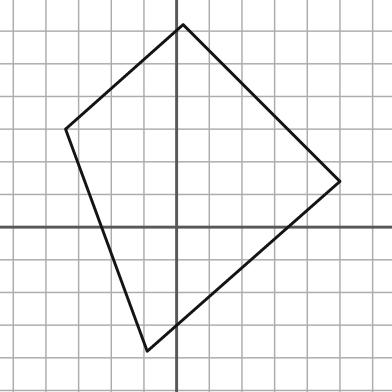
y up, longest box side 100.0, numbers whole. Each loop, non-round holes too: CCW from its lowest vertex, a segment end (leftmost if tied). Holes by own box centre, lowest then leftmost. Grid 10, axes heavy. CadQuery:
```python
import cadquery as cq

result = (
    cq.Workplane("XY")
    .moveTo(-9.0, -38.0)
    .lineTo(50.0, 14.0)
    .lineTo(2.0, 62.0)
    .lineTo(-34.0, 30.0)
    .close()
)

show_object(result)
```